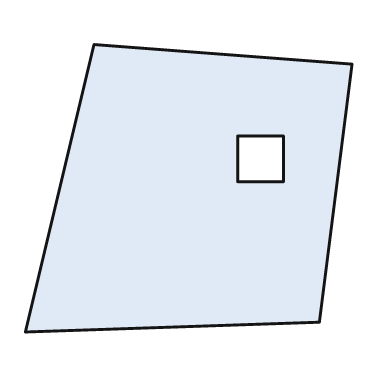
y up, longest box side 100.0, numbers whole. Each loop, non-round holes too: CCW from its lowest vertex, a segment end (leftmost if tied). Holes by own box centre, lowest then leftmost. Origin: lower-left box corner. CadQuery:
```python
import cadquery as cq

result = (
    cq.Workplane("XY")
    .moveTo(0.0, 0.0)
    .lineTo(90.0, 3.0)
    .lineTo(100.0, 82.0)
    .lineTo(21.0, 88.0)
    .close()
    .moveTo(65.0, 46.0)
    .lineTo(79.0, 46.0)
    .lineTo(79.0, 60.0)
    .lineTo(65.0, 60.0)
    .close()
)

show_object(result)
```